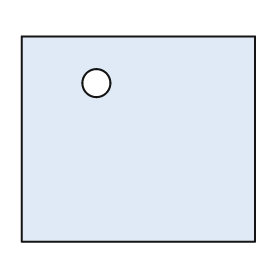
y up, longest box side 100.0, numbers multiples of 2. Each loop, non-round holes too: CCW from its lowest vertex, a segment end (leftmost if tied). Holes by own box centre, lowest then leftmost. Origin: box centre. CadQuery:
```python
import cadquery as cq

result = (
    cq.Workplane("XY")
    .moveTo(-50.0, -44.0)
    .lineTo(50.0, -44.0)
    .lineTo(50.0, 44.0)
    .lineTo(-50.0, 44.0)
    .close()
    .moveTo(-18.0, 24.0)
    .circle(6.0)
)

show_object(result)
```